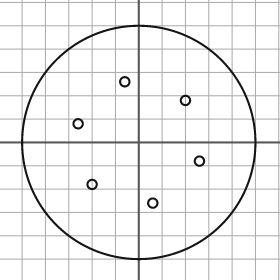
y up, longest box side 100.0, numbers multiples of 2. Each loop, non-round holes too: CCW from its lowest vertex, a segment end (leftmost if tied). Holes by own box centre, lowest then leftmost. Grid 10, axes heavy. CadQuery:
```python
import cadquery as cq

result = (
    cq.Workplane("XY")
    .moveTo(0.0, 0.0)
    .circle(50.0)
    .moveTo(6.0, -26.0)
    .circle(2.0)
    .moveTo(-20.0, -18.0)
    .circle(2.0)
    .moveTo(26.0, -8.0)
    .circle(2.0)
    .moveTo(-26.0, 8.0)
    .circle(2.0)
    .moveTo(20.0, 18.0)
    .circle(2.0)
    .moveTo(-6.0, 26.0)
    .circle(2.0)
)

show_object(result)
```